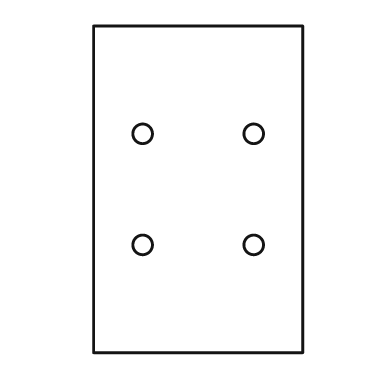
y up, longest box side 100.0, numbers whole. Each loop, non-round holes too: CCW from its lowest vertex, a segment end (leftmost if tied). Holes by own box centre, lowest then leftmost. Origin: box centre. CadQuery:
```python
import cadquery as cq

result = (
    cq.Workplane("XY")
    .moveTo(-32.0, -50.0)
    .lineTo(32.0, -50.0)
    .lineTo(32.0, 50.0)
    .lineTo(-32.0, 50.0)
    .close()
    .moveTo(-17.0, -17.0)
    .circle(3.0)
    .moveTo(17.0, -17.0)
    .circle(3.0)
    .moveTo(-17.0, 17.0)
    .circle(3.0)
    .moveTo(17.0, 17.0)
    .circle(3.0)
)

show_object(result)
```